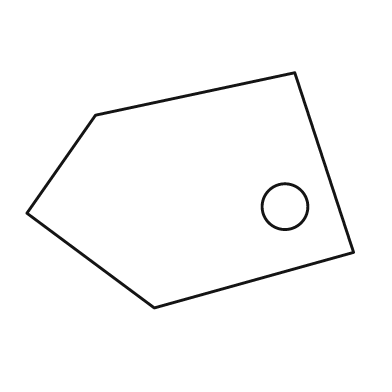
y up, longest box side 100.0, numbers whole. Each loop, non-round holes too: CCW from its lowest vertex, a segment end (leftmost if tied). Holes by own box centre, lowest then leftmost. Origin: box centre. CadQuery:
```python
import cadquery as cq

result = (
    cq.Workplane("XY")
    .moveTo(-11.0, -36.0)
    .lineTo(50.0, -19.0)
    .lineTo(32.0, 36.0)
    .lineTo(-29.0, 23.0)
    .lineTo(-50.0, -7.0)
    .close()
    .moveTo(29.0, -5.0)
    .circle(7.0)
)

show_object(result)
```